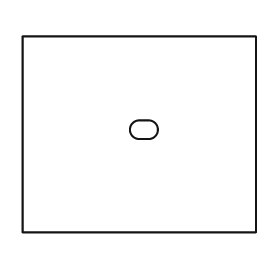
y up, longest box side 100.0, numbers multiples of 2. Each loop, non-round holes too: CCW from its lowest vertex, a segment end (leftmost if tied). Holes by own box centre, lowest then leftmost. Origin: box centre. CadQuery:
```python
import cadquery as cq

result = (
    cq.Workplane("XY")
    .moveTo(-50.0, -42.0)
    .lineTo(50.0, -42.0)
    .lineTo(50.0, 42.0)
    .lineTo(-50.0, 42.0)
    .close()
    .moveTo(0.0, -2.0)
    .lineTo(4.0, -2.0)
    .threePointArc((8.0, 2.0), (4.0, 6.0))
    .lineTo(0.0, 6.0)
    .threePointArc((-4.0, 2.0), (0.0, -2.0))
    .close()
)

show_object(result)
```